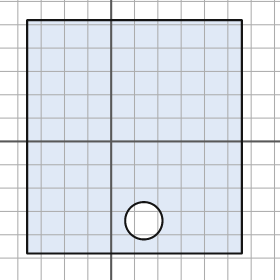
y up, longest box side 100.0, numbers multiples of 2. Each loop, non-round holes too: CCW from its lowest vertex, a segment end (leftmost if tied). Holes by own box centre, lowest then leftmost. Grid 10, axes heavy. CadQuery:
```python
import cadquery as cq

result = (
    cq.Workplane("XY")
    .moveTo(-36.0, -48.0)
    .lineTo(56.0, -48.0)
    .lineTo(56.0, 52.0)
    .lineTo(-36.0, 52.0)
    .close()
    .moveTo(14.0, -34.0)
    .circle(8.0)
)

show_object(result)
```